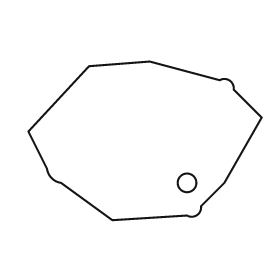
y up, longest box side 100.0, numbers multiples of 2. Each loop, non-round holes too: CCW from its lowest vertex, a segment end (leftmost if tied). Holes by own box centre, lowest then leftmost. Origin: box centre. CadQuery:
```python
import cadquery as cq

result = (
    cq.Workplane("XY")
    .moveTo(-14.0, -34.0)
    .lineTo(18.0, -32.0)
    .threePointArc((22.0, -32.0), (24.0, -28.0))
    .lineTo(34.0, -18.0)
    .lineTo(50.0, 10.0)
    .lineTo(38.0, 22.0)
    .threePointArc((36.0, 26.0), (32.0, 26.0))
    .lineTo(2.0, 34.0)
    .lineTo(-24.0, 32.0)
    .lineTo(-50.0, 4.0)
    .lineTo(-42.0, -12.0)
    .threePointArc((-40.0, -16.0), (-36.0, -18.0))
    .close()
    .moveTo(18.0, -18.0)
    .circle(4.0)
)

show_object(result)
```